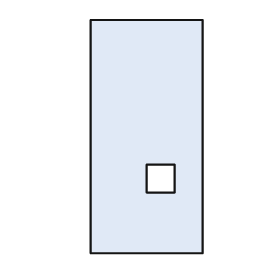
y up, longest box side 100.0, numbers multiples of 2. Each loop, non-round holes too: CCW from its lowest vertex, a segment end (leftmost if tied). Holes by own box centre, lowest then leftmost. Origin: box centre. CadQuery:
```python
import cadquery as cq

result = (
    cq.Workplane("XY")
    .moveTo(-24.0, -50.0)
    .lineTo(24.0, -50.0)
    .lineTo(24.0, 50.0)
    .lineTo(-24.0, 50.0)
    .close()
    .moveTo(0.0, -24.0)
    .lineTo(12.0, -24.0)
    .lineTo(12.0, -12.0)
    .lineTo(0.0, -12.0)
    .close()
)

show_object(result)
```